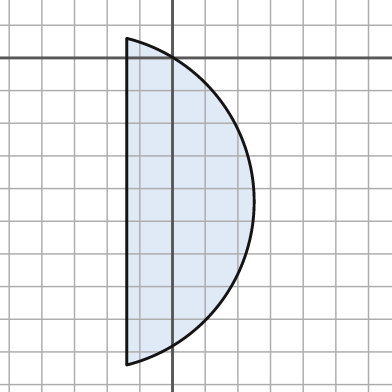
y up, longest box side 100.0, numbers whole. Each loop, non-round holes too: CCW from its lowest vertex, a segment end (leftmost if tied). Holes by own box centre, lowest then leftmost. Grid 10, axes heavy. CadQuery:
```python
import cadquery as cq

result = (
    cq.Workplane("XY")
    .moveTo(-14.0, -94.0)
    .threePointArc((25.0, -44.0), (-14.0, 6.0))
    .close()
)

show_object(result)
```